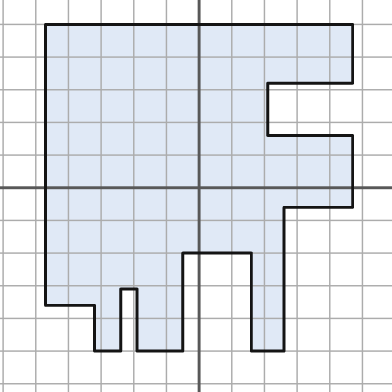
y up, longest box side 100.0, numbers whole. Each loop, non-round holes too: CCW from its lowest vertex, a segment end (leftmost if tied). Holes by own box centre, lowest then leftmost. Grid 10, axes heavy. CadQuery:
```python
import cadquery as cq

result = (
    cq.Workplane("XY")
    .moveTo(-32.0, -50.0)
    .lineTo(-24.0, -50.0)
    .lineTo(-24.0, -31.0)
    .lineTo(-19.0, -31.0)
    .lineTo(-19.0, -50.0)
    .lineTo(-5.0, -50.0)
    .lineTo(-5.0, -20.0)
    .lineTo(16.0, -20.0)
    .lineTo(16.0, -50.0)
    .lineTo(26.0, -50.0)
    .lineTo(26.0, -6.0)
    .lineTo(47.0, -6.0)
    .lineTo(47.0, 16.0)
    .lineTo(21.0, 16.0)
    .lineTo(21.0, 32.0)
    .lineTo(47.0, 32.0)
    .lineTo(47.0, 50.0)
    .lineTo(-47.0, 50.0)
    .lineTo(-47.0, -36.0)
    .lineTo(-32.0, -36.0)
    .close()
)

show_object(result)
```